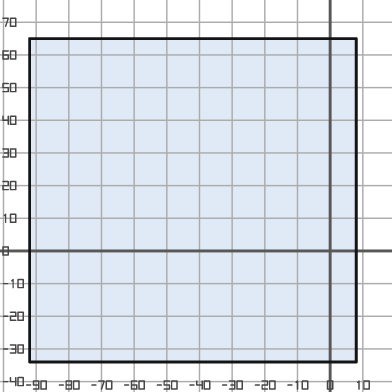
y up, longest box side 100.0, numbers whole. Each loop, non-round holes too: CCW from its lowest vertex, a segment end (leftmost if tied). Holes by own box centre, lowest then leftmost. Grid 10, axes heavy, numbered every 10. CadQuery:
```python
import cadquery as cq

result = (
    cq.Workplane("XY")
    .moveTo(-92.0, -34.0)
    .lineTo(8.0, -34.0)
    .lineTo(8.0, 65.0)
    .lineTo(-92.0, 65.0)
    .close()
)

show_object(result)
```